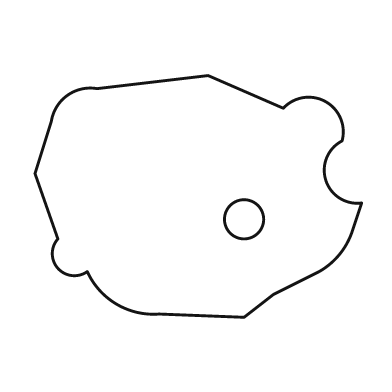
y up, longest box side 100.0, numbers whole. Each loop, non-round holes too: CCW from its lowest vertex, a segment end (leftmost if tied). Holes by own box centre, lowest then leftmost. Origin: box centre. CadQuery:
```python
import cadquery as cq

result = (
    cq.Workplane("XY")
    .moveTo(14.0, -37.0)
    .lineTo(23.0, -30.0)
    .lineTo(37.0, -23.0)
    .threePointArc((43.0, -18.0), (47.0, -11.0))
    .lineTo(50.0, -2.0)
    .threePointArc((39.0, 5.0), (44.0, 17.0))
    .threePointArc((39.0, 29.0), (26.0, 27.0))
    .lineTo(3.0, 37.0)
    .lineTo(-31.0, 33.0)
    .threePointArc((-40.0, 31.0), (-45.0, 23.0))
    .lineTo(-50.0, 7.0)
    .lineTo(-43.0, -13.0)
    .threePointArc((-43.0, -22.0), (-34.0, -23.0))
    .threePointArc((-25.0, -33.0), (-12.0, -36.0))
    .close()
    .moveTo(14.0, -7.0)
    .circle(6.0)
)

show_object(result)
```